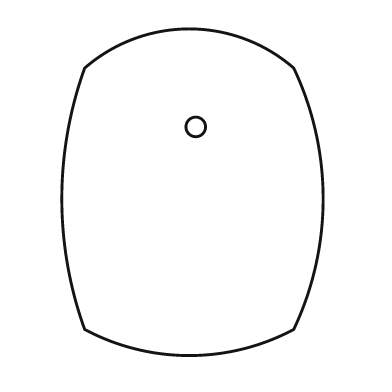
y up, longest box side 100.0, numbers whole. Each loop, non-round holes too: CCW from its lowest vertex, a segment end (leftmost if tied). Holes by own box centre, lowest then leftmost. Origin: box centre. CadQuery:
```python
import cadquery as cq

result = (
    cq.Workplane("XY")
    .moveTo(-33.0, -42.0)
    .threePointArc((-1.0, -50.0), (31.0, -42.0))
    .threePointArc((40.0, -2.0), (31.0, 38.0))
    .threePointArc((-1.0, 50.0), (-33.0, 38.0))
    .threePointArc((-40.0, -2.0), (-33.0, -42.0))
    .close()
    .moveTo(1.0, 20.0)
    .circle(3.0)
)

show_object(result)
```